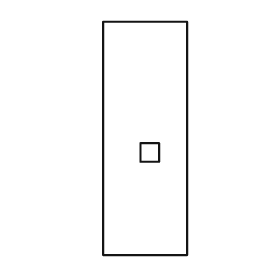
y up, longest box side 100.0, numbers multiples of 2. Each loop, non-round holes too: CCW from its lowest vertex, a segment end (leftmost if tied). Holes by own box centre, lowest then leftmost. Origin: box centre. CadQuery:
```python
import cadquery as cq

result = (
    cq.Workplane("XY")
    .moveTo(-18.0, -50.0)
    .lineTo(18.0, -50.0)
    .lineTo(18.0, 50.0)
    .lineTo(-18.0, 50.0)
    .close()
    .moveTo(-2.0, -10.0)
    .lineTo(6.0, -10.0)
    .lineTo(6.0, -2.0)
    .lineTo(-2.0, -2.0)
    .close()
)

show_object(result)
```